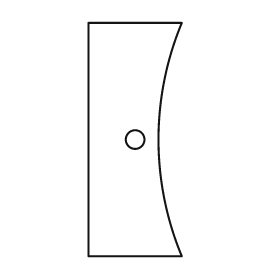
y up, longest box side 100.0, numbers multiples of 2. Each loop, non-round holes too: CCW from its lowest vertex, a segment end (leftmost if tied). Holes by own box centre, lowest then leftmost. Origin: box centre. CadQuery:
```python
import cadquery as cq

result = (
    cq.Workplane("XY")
    .moveTo(-20.0, -50.0)
    .lineTo(20.0, -50.0)
    .threePointArc((10.0, 0.0), (20.0, 50.0))
    .lineTo(-20.0, 50.0)
    .close()
    .moveTo(0.0, 0.0)
    .circle(4.0)
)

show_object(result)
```